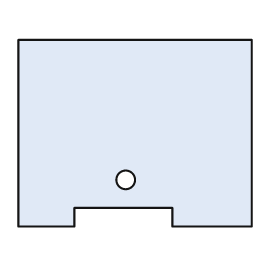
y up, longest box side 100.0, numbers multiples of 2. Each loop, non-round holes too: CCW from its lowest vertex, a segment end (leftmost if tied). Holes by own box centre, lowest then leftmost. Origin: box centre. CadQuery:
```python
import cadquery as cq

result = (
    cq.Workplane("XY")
    .moveTo(-50.0, -40.0)
    .lineTo(-26.0, -40.0)
    .lineTo(-26.0, -32.0)
    .lineTo(16.0, -32.0)
    .lineTo(16.0, -40.0)
    .lineTo(50.0, -40.0)
    .lineTo(50.0, 40.0)
    .lineTo(-50.0, 40.0)
    .close()
    .moveTo(-4.0, -20.0)
    .circle(4.0)
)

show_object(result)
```